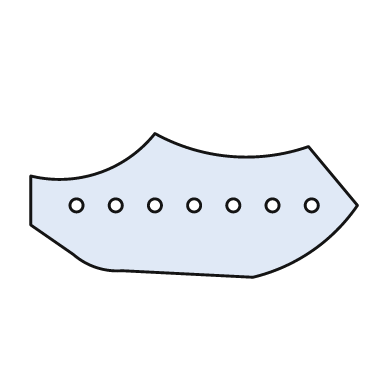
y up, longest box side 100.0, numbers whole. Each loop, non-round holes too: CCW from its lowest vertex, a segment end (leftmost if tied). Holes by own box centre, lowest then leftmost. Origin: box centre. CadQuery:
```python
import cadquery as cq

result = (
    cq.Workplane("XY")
    .moveTo(18.0, -22.0)
    .threePointArc((36.0, -14.0), (50.0, 0.0))
    .lineTo(35.0, 18.0)
    .threePointArc((11.0, 15.0), (-12.0, 22.0))
    .threePointArc((-29.0, 10.0), (-50.0, 9.0))
    .lineTo(-50.0, -6.0)
    .lineTo(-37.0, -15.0)
    .threePointArc((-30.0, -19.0), (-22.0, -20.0))
    .close()
    .moveTo(-36.0, 0.0)
    .circle(2.0)
    .moveTo(-24.0, 0.0)
    .circle(2.0)
    .moveTo(-12.0, 0.0)
    .circle(2.0)
    .moveTo(0.0, 0.0)
    .circle(2.0)
    .moveTo(12.0, 0.0)
    .circle(2.0)
    .moveTo(24.0, 0.0)
    .circle(2.0)
    .moveTo(36.0, 0.0)
    .circle(2.0)
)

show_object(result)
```